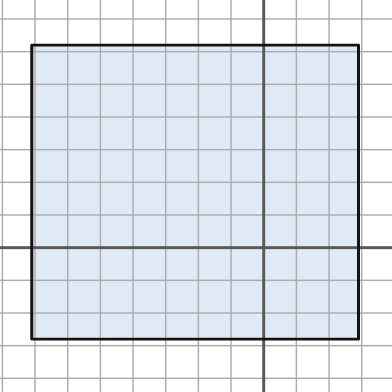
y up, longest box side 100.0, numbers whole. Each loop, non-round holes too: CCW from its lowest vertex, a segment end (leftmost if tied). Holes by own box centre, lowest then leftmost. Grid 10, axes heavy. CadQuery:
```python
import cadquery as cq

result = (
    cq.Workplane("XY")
    .moveTo(-71.0, -28.0)
    .lineTo(29.0, -28.0)
    .lineTo(29.0, 62.0)
    .lineTo(-71.0, 62.0)
    .close()
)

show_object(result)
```